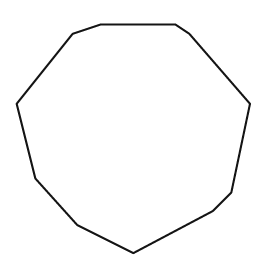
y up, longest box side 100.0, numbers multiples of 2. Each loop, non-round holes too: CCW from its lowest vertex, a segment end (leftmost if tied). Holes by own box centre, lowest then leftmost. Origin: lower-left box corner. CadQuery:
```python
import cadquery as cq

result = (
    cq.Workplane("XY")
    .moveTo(50.0, 0.0)
    .lineTo(84.0, 18.0)
    .lineTo(92.0, 26.0)
    .lineTo(100.0, 64.0)
    .lineTo(74.0, 94.0)
    .lineTo(68.0, 98.0)
    .lineTo(36.0, 98.0)
    .lineTo(24.0, 94.0)
    .lineTo(0.0, 64.0)
    .lineTo(8.0, 32.0)
    .lineTo(26.0, 12.0)
    .close()
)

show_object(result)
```